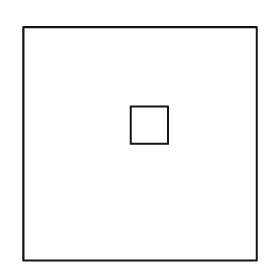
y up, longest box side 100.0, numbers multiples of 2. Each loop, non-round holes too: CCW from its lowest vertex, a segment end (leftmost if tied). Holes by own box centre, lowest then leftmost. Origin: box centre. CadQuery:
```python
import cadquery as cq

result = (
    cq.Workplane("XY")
    .moveTo(-50.0, -50.0)
    .lineTo(50.0, -50.0)
    .lineTo(50.0, 50.0)
    .lineTo(-50.0, 50.0)
    .close()
    .moveTo(-4.0, 0.0)
    .lineTo(12.0, 0.0)
    .lineTo(12.0, 16.0)
    .lineTo(-4.0, 16.0)
    .close()
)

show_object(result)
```